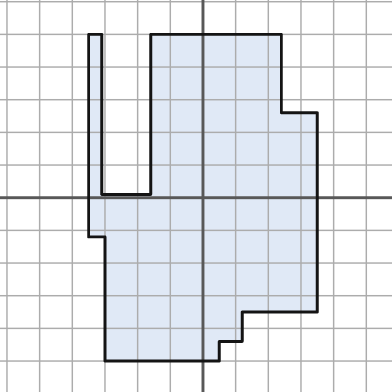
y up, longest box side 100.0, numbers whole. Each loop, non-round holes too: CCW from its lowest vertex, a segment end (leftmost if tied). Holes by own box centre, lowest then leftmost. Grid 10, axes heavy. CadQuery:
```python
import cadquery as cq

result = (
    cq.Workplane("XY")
    .moveTo(-30.0, -50.0)
    .lineTo(5.0, -50.0)
    .lineTo(5.0, -44.0)
    .lineTo(12.0, -44.0)
    .lineTo(12.0, -35.0)
    .lineTo(35.0, -35.0)
    .lineTo(35.0, 26.0)
    .lineTo(24.0, 26.0)
    .lineTo(24.0, 50.0)
    .lineTo(-16.0, 50.0)
    .lineTo(-16.0, 1.0)
    .lineTo(-31.0, 1.0)
    .lineTo(-31.0, 50.0)
    .lineTo(-35.0, 50.0)
    .lineTo(-35.0, -12.0)
    .lineTo(-30.0, -12.0)
    .close()
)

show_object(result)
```